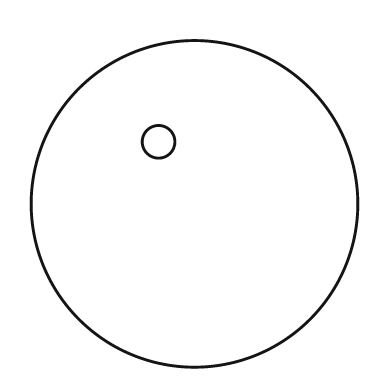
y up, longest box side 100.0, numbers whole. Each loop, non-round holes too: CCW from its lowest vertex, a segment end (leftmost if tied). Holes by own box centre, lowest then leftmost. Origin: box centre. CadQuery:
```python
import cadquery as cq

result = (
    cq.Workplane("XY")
    .moveTo(0.0, 0.0)
    .circle(50.0)
    .moveTo(-11.0, 19.0)
    .circle(5.0)
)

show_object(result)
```